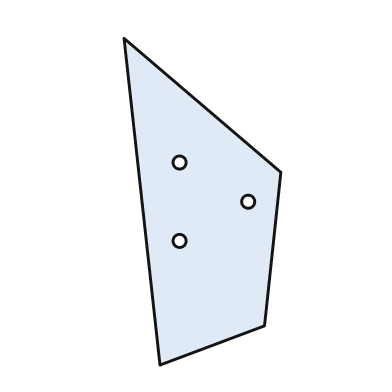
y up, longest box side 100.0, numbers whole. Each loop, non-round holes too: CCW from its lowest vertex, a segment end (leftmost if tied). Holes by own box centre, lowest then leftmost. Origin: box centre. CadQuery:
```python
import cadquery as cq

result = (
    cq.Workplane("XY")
    .moveTo(-13.0, -50.0)
    .lineTo(19.0, -38.0)
    .lineTo(24.0, 9.0)
    .lineTo(-24.0, 50.0)
    .close()
    .moveTo(-7.0, -12.0)
    .circle(2.0)
    .moveTo(14.0, 0.0)
    .circle(2.0)
    .moveTo(-7.0, 12.0)
    .circle(2.0)
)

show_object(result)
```